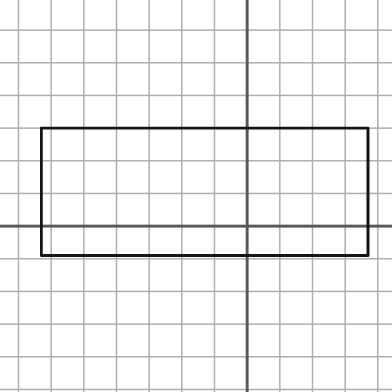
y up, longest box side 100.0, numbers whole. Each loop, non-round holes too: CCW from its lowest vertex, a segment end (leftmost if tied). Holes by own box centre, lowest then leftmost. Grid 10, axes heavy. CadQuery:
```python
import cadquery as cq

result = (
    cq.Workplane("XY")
    .moveTo(-63.0, -9.0)
    .lineTo(37.0, -9.0)
    .lineTo(37.0, 30.0)
    .lineTo(-63.0, 30.0)
    .close()
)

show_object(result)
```